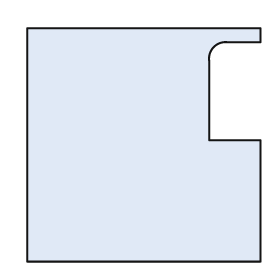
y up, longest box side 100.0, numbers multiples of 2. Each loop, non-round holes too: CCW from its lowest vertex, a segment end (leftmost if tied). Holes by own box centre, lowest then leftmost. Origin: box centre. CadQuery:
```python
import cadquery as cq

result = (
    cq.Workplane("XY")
    .moveTo(-50.0, -50.0)
    .lineTo(50.0, -50.0)
    .lineTo(50.0, 2.0)
    .lineTo(28.0, 2.0)
    .lineTo(28.0, 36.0)
    .threePointArc((30.0, 42.0), (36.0, 44.0))
    .lineTo(50.0, 44.0)
    .lineTo(50.0, 50.0)
    .lineTo(-50.0, 50.0)
    .close()
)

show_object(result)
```